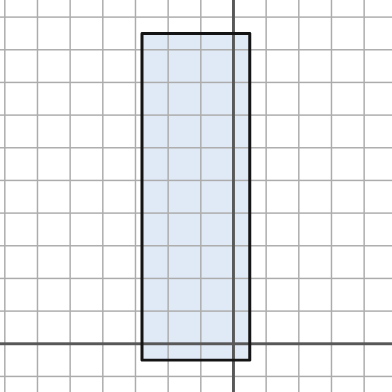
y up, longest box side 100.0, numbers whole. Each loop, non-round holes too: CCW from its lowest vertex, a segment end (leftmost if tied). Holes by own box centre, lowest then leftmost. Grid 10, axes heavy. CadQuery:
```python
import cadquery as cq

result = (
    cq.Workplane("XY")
    .moveTo(-28.0, -5.0)
    .lineTo(5.0, -5.0)
    .lineTo(5.0, 95.0)
    .lineTo(-28.0, 95.0)
    .close()
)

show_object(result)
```